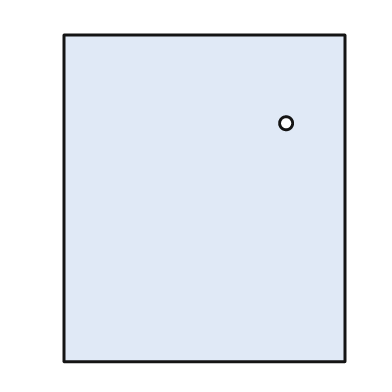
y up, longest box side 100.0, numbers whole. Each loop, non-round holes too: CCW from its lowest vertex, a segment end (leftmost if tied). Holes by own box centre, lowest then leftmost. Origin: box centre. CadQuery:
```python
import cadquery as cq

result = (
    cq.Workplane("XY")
    .moveTo(-43.0, -50.0)
    .lineTo(43.0, -50.0)
    .lineTo(43.0, 50.0)
    .lineTo(-43.0, 50.0)
    .close()
    .moveTo(25.0, 23.0)
    .circle(2.0)
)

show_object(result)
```